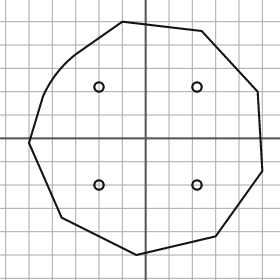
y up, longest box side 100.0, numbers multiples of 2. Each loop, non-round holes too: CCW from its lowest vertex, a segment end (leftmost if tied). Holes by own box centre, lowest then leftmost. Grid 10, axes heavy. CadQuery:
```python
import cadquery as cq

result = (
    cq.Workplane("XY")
    .moveTo(-4.0, -50.0)
    .lineTo(30.0, -42.0)
    .lineTo(50.0, -14.0)
    .lineTo(48.0, 20.0)
    .lineTo(24.0, 46.0)
    .lineTo(-10.0, 50.0)
    .lineTo(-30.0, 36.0)
    .threePointArc((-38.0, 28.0), (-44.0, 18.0))
    .lineTo(-50.0, -2.0)
    .lineTo(-36.0, -34.0)
    .close()
    .moveTo(-20.0, -20.0)
    .circle(2.0)
    .moveTo(22.0, -20.0)
    .circle(2.0)
    .moveTo(-20.0, 22.0)
    .circle(2.0)
    .moveTo(22.0, 22.0)
    .circle(2.0)
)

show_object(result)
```